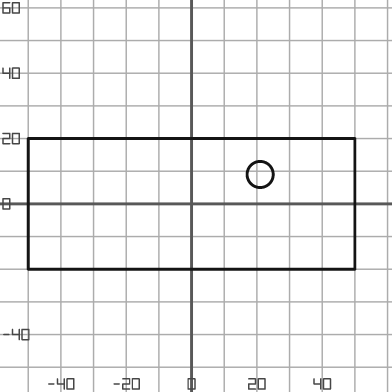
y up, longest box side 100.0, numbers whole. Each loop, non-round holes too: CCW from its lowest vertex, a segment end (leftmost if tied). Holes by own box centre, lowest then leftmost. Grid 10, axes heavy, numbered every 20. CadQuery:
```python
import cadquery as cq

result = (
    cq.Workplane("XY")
    .moveTo(-50.0, -20.0)
    .lineTo(50.0, -20.0)
    .lineTo(50.0, 20.0)
    .lineTo(-50.0, 20.0)
    .close()
    .moveTo(21.0, 9.0)
    .circle(4.0)
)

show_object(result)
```